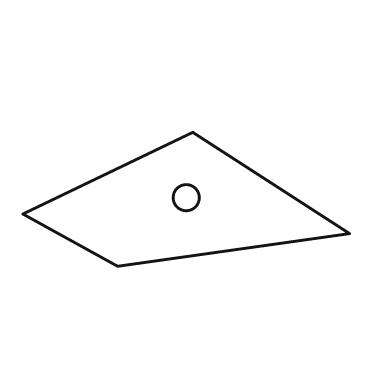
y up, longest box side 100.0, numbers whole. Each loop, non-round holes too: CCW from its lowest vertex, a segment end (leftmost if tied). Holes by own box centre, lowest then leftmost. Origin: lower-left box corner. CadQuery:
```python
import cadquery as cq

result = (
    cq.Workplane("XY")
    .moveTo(29.0, 0.0)
    .lineTo(100.0, 10.0)
    .lineTo(52.0, 41.0)
    .lineTo(0.0, 16.0)
    .close()
    .moveTo(50.0, 21.0)
    .circle(4.0)
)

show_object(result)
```